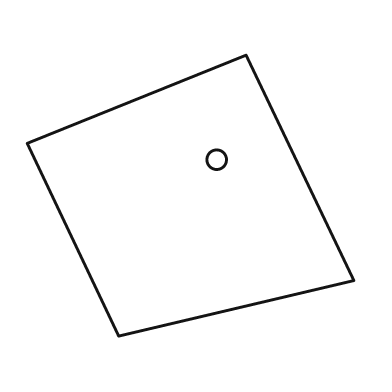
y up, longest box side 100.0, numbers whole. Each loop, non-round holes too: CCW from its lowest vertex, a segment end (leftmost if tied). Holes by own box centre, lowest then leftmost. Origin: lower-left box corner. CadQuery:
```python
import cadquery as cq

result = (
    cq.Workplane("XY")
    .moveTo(28.0, 0.0)
    .lineTo(100.0, 17.0)
    .lineTo(67.0, 86.0)
    .lineTo(0.0, 59.0)
    .close()
    .moveTo(58.0, 54.0)
    .circle(3.0)
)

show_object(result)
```